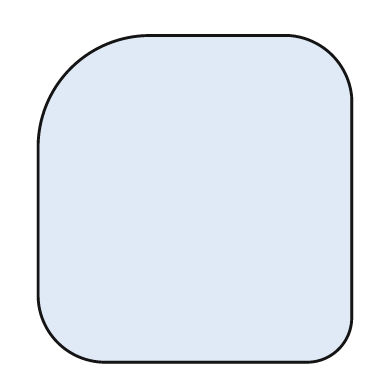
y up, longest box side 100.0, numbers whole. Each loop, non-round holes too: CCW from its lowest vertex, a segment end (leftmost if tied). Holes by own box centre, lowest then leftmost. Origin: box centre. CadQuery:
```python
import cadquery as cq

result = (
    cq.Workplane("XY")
    .moveTo(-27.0, -50.0)
    .lineTo(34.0, -50.0)
    .threePointArc((44.0, -46.0), (48.0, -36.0))
    .lineTo(48.0, 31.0)
    .threePointArc((42.0, 44.0), (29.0, 50.0))
    .lineTo(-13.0, 50.0)
    .threePointArc((-38.0, 40.0), (-48.0, 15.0))
    .lineTo(-48.0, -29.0)
    .threePointArc((-42.0, -44.0), (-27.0, -50.0))
    .close()
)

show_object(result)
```